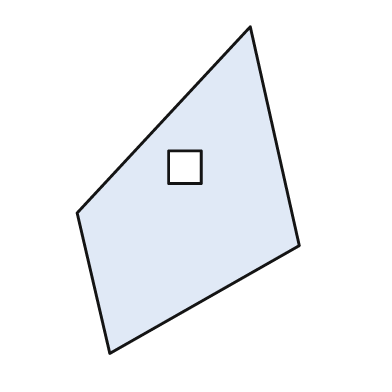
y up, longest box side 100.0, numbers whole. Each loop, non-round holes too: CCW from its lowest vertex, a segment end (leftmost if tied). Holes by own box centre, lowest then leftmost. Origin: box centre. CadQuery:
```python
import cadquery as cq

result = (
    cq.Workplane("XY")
    .moveTo(-24.0, -50.0)
    .lineTo(34.0, -17.0)
    .lineTo(19.0, 50.0)
    .lineTo(-34.0, -7.0)
    .close()
    .moveTo(-6.0, 2.0)
    .lineTo(4.0, 2.0)
    .lineTo(4.0, 12.0)
    .lineTo(-6.0, 12.0)
    .close()
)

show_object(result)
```